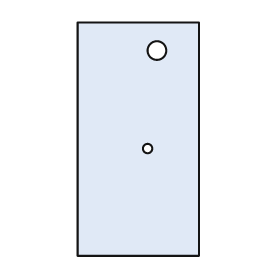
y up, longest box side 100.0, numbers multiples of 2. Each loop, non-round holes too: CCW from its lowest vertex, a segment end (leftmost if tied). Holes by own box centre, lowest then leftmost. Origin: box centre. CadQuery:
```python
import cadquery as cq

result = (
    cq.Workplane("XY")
    .moveTo(-26.0, -50.0)
    .lineTo(26.0, -50.0)
    .lineTo(26.0, 50.0)
    .lineTo(-26.0, 50.0)
    .close()
    .moveTo(4.0, -4.0)
    .circle(2.0)
    .moveTo(8.0, 38.0)
    .circle(4.0)
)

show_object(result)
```